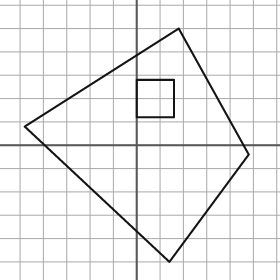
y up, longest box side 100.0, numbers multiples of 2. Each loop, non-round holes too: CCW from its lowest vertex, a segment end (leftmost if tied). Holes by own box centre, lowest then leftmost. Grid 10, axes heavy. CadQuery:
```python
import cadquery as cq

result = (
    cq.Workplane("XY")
    .moveTo(14.0, -50.0)
    .lineTo(48.0, -4.0)
    .lineTo(18.0, 50.0)
    .lineTo(-48.0, 8.0)
    .close()
    .moveTo(0.0, 12.0)
    .lineTo(16.0, 12.0)
    .lineTo(16.0, 28.0)
    .lineTo(0.0, 28.0)
    .close()
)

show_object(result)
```